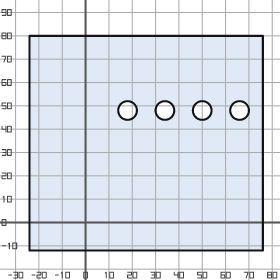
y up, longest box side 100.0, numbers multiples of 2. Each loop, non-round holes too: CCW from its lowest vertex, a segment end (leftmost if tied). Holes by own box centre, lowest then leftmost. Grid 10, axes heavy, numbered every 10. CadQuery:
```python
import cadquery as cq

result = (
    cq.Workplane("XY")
    .moveTo(-24.0, -12.0)
    .lineTo(76.0, -12.0)
    .lineTo(76.0, 80.0)
    .lineTo(-24.0, 80.0)
    .close()
    .moveTo(18.0, 48.0)
    .circle(4.0)
    .moveTo(34.0, 48.0)
    .circle(4.0)
    .moveTo(50.0, 48.0)
    .circle(4.0)
    .moveTo(66.0, 48.0)
    .circle(4.0)
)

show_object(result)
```